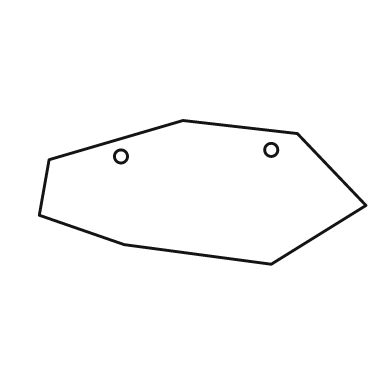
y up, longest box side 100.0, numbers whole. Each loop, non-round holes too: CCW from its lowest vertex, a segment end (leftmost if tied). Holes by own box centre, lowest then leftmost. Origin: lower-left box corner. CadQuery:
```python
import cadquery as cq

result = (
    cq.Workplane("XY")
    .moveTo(71.0, 0.0)
    .lineTo(100.0, 18.0)
    .lineTo(79.0, 40.0)
    .lineTo(44.0, 44.0)
    .lineTo(3.0, 32.0)
    .lineTo(0.0, 15.0)
    .lineTo(26.0, 6.0)
    .close()
    .moveTo(25.0, 33.0)
    .circle(2.0)
    .moveTo(71.0, 35.0)
    .circle(2.0)
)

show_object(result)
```